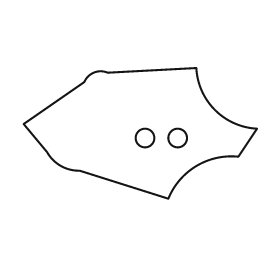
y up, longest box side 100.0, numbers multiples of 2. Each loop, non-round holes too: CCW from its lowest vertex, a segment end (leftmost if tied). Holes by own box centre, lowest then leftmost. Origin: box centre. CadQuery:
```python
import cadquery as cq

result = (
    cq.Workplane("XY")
    .moveTo(12.0, -28.0)
    .threePointArc((24.0, -14.0), (42.0, -10.0))
    .lineTo(50.0, 2.0)
    .threePointArc((32.0, 10.0), (24.0, 28.0))
    .lineTo(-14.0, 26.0)
    .threePointArc((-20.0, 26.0), (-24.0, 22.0))
    .lineTo(-50.0, 4.0)
    .lineTo(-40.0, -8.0)
    .threePointArc((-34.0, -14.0), (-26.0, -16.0))
    .close()
    .moveTo(2.0, -2.0)
    .circle(4.0)
    .moveTo(16.0, -2.0)
    .circle(4.0)
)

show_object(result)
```